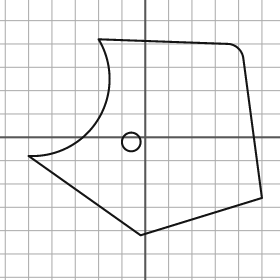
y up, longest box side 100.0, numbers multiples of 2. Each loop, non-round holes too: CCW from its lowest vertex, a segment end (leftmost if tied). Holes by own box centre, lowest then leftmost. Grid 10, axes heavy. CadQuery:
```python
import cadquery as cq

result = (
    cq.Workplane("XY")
    .moveTo(-2.0, -42.0)
    .lineTo(50.0, -26.0)
    .lineTo(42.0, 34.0)
    .threePointArc((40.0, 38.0), (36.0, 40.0))
    .lineTo(-20.0, 42.0)
    .threePointArc((-20.0, 8.0), (-50.0, -8.0))
    .close()
    .moveTo(-6.0, -2.0)
    .circle(4.0)
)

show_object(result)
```